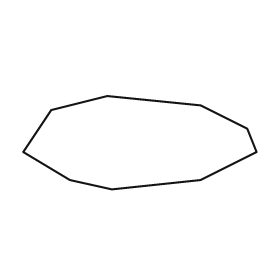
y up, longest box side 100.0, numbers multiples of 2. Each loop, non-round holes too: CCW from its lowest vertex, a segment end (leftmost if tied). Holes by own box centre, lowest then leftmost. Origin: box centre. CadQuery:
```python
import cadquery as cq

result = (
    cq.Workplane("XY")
    .moveTo(-12.0, -20.0)
    .lineTo(26.0, -16.0)
    .lineTo(50.0, -4.0)
    .lineTo(46.0, 6.0)
    .lineTo(26.0, 16.0)
    .lineTo(-14.0, 20.0)
    .lineTo(-38.0, 14.0)
    .lineTo(-50.0, -4.0)
    .lineTo(-30.0, -16.0)
    .close()
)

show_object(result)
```